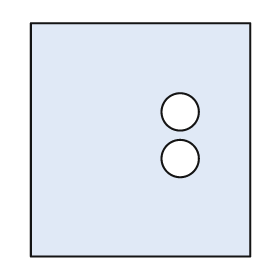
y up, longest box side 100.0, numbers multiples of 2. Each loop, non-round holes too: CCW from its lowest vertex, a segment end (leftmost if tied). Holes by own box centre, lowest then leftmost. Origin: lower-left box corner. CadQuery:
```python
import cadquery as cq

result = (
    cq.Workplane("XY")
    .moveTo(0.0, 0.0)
    .lineTo(94.0, 0.0)
    .lineTo(94.0, 100.0)
    .lineTo(0.0, 100.0)
    .close()
    .moveTo(64.0, 42.0)
    .circle(8.0)
    .moveTo(64.0, 62.0)
    .circle(8.0)
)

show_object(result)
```